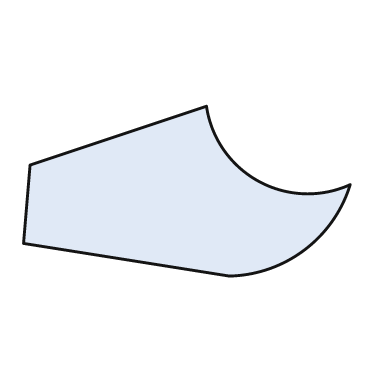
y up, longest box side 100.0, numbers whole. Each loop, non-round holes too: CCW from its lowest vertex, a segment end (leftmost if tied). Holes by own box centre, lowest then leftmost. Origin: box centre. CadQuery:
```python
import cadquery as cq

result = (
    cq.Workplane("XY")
    .moveTo(13.0, -26.0)
    .threePointArc((36.0, -18.0), (50.0, 2.0))
    .threePointArc((22.0, 3.0), (6.0, 26.0))
    .lineTo(-48.0, 8.0)
    .lineTo(-50.0, -16.0)
    .close()
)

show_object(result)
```